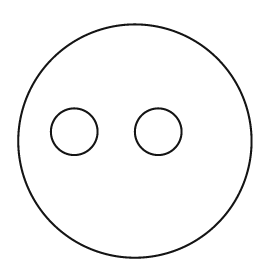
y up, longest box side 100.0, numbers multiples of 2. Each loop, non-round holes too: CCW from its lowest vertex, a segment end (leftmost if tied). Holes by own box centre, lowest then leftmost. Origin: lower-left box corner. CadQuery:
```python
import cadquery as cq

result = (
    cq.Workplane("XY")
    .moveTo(50.0, 50.0)
    .circle(50.0)
    .moveTo(24.0, 54.0)
    .circle(10.0)
    .moveTo(60.0, 54.0)
    .circle(10.0)
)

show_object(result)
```